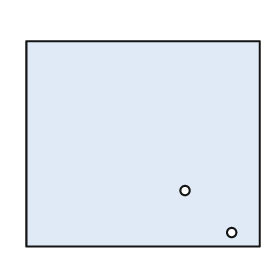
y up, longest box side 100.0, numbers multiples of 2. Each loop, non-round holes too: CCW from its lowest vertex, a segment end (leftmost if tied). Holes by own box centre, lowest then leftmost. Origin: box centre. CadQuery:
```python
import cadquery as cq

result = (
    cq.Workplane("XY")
    .moveTo(-50.0, -44.0)
    .lineTo(50.0, -44.0)
    .lineTo(50.0, 44.0)
    .lineTo(-50.0, 44.0)
    .close()
    .moveTo(38.0, -38.0)
    .circle(2.0)
    .moveTo(18.0, -20.0)
    .circle(2.0)
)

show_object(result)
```